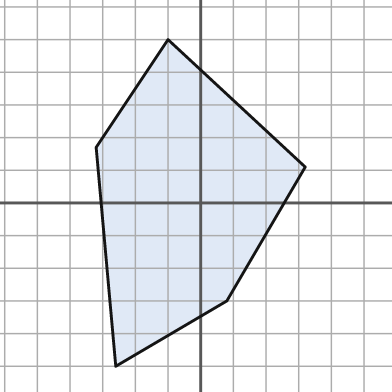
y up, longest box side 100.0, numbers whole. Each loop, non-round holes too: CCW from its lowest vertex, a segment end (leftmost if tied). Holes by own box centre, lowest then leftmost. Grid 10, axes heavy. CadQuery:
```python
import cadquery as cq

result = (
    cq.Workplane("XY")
    .moveTo(-26.0, -50.0)
    .lineTo(8.0, -30.0)
    .lineTo(32.0, 11.0)
    .lineTo(-10.0, 50.0)
    .lineTo(-32.0, 17.0)
    .close()
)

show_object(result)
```